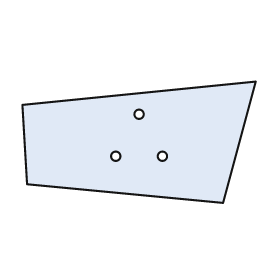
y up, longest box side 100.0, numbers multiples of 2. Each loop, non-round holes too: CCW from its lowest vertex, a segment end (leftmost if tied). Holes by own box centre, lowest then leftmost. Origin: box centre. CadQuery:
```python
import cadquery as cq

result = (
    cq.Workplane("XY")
    .moveTo(36.0, -26.0)
    .lineTo(50.0, 26.0)
    .lineTo(-50.0, 16.0)
    .lineTo(-48.0, -18.0)
    .close()
    .moveTo(-10.0, -6.0)
    .circle(2.0)
    .moveTo(10.0, -6.0)
    .circle(2.0)
    .moveTo(0.0, 12.0)
    .circle(2.0)
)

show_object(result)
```